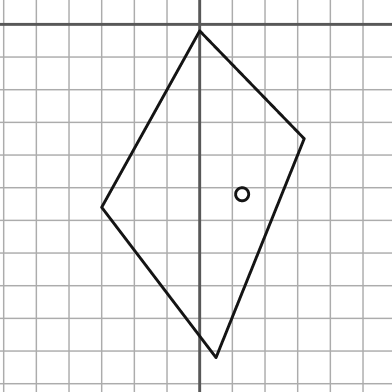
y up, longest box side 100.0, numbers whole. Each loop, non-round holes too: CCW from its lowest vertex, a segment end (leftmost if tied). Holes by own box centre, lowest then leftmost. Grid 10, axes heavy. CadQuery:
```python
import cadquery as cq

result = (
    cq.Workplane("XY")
    .moveTo(5.0, -102.0)
    .lineTo(32.0, -35.0)
    .lineTo(0.0, -2.0)
    .lineTo(-30.0, -56.0)
    .close()
    .moveTo(13.0, -52.0)
    .circle(2.0)
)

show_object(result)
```